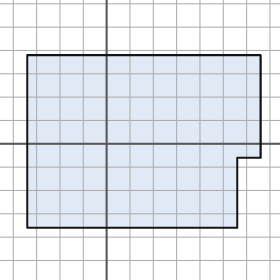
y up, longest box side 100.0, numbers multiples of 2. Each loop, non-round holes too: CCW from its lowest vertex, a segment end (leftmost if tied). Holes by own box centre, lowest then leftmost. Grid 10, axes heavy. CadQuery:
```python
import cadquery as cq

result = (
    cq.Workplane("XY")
    .moveTo(-34.0, -36.0)
    .lineTo(56.0, -36.0)
    .lineTo(56.0, -6.0)
    .lineTo(66.0, -6.0)
    .lineTo(66.0, 38.0)
    .lineTo(-34.0, 38.0)
    .close()
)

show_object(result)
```